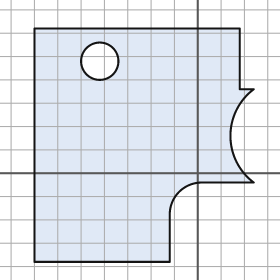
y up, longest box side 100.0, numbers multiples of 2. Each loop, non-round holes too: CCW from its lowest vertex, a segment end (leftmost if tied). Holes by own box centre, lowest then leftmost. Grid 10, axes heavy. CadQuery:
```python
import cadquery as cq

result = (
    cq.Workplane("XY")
    .moveTo(-70.0, -38.0)
    .lineTo(-12.0, -38.0)
    .lineTo(-12.0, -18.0)
    .threePointArc((-8.0, -8.0), (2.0, -4.0))
    .lineTo(24.0, -4.0)
    .threePointArc((14.0, 16.0), (24.0, 36.0))
    .lineTo(18.0, 36.0)
    .lineTo(18.0, 62.0)
    .lineTo(-70.0, 62.0)
    .close()
    .moveTo(-42.0, 48.0)
    .circle(8.0)
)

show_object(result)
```